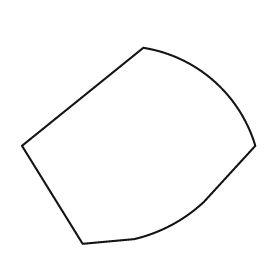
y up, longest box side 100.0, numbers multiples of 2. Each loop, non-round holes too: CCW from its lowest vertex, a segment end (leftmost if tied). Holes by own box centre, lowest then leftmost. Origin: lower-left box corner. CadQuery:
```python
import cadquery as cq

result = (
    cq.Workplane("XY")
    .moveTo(26.0, 0.0)
    .lineTo(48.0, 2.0)
    .threePointArc((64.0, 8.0), (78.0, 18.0))
    .lineTo(100.0, 42.0)
    .threePointArc((82.0, 70.0), (52.0, 84.0))
    .lineTo(0.0, 42.0)
    .close()
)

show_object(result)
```